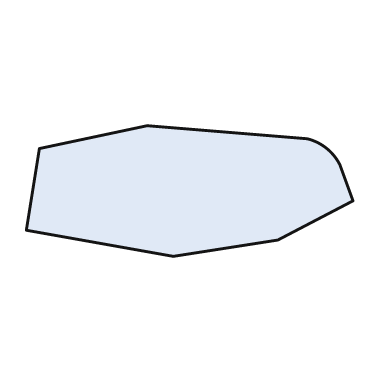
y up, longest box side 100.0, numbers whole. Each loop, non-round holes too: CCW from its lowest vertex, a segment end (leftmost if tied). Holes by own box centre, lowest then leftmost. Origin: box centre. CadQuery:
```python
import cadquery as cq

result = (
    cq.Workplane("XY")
    .moveTo(-5.0, -20.0)
    .lineTo(27.0, -15.0)
    .lineTo(50.0, -3.0)
    .lineTo(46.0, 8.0)
    .threePointArc((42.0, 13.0), (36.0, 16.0))
    .lineTo(-13.0, 20.0)
    .lineTo(-46.0, 13.0)
    .lineTo(-50.0, -12.0)
    .close()
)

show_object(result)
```